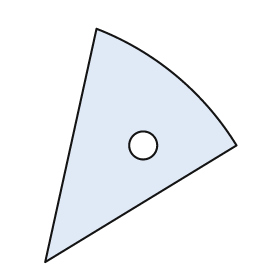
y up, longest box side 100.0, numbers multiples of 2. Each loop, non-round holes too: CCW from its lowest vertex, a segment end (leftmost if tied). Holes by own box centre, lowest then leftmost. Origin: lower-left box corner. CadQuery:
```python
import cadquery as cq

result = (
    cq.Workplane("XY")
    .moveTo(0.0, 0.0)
    .lineTo(82.0, 50.0)
    .threePointArc((56.0, 80.0), (22.0, 100.0))
    .close()
    .moveTo(42.0, 50.0)
    .circle(6.0)
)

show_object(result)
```